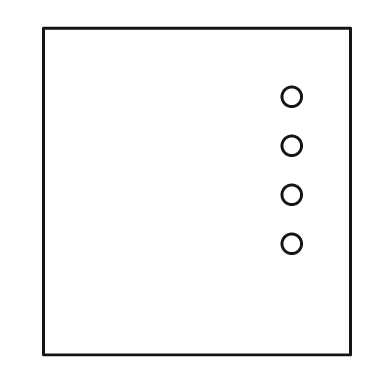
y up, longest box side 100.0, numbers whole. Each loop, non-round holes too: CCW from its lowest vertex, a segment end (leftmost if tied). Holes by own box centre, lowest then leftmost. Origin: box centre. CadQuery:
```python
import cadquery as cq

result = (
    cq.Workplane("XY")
    .moveTo(-47.0, -50.0)
    .lineTo(47.0, -50.0)
    .lineTo(47.0, 50.0)
    .lineTo(-47.0, 50.0)
    .close()
    .moveTo(29.0, -16.0)
    .circle(3.0)
    .moveTo(29.0, -1.0)
    .circle(3.0)
    .moveTo(29.0, 14.0)
    .circle(3.0)
    .moveTo(29.0, 29.0)
    .circle(3.0)
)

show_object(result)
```